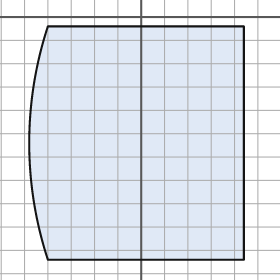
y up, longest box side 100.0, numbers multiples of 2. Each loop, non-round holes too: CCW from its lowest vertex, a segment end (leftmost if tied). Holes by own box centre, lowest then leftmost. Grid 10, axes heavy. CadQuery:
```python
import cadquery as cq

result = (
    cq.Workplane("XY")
    .moveTo(-40.0, -104.0)
    .lineTo(44.0, -104.0)
    .lineTo(44.0, -4.0)
    .lineTo(-40.0, -4.0)
    .threePointArc((-48.0, -54.0), (-40.0, -104.0))
    .close()
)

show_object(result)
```